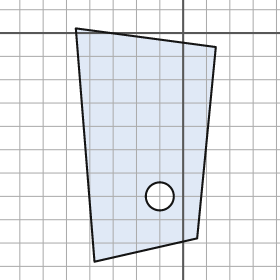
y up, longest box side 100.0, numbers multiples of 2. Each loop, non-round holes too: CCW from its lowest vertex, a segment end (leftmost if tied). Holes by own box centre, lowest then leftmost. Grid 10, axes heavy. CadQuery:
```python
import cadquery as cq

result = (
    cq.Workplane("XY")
    .moveTo(-38.0, -98.0)
    .lineTo(6.0, -88.0)
    .lineTo(14.0, -6.0)
    .lineTo(-46.0, 2.0)
    .close()
    .moveTo(-10.0, -70.0)
    .circle(6.0)
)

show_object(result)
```